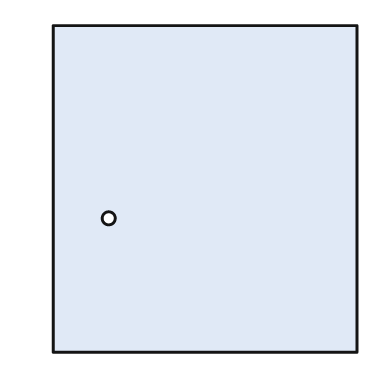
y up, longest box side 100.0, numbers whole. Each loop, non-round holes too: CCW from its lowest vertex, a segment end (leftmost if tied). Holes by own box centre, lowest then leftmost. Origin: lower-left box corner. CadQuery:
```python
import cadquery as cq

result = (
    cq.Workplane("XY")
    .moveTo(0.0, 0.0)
    .lineTo(93.0, 0.0)
    .lineTo(93.0, 100.0)
    .lineTo(0.0, 100.0)
    .close()
    .moveTo(17.0, 41.0)
    .circle(2.0)
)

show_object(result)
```